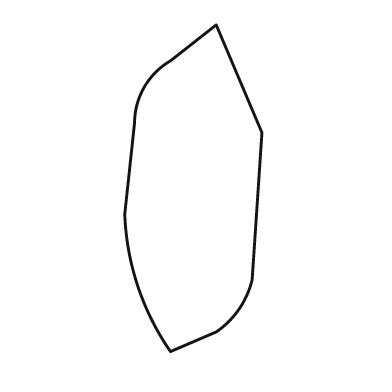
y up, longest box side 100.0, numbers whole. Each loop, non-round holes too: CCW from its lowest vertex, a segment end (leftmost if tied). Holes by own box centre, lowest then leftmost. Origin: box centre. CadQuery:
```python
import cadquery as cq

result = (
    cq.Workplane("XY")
    .moveTo(-7.0, -50.0)
    .lineTo(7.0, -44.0)
    .threePointArc((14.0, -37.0), (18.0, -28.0))
    .lineTo(21.0, 17.0)
    .lineTo(7.0, 50.0)
    .lineTo(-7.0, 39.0)
    .threePointArc((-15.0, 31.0), (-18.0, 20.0))
    .lineTo(-21.0, -8.0)
    .threePointArc((-17.0, -30.0), (-7.0, -50.0))
    .close()
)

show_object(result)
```